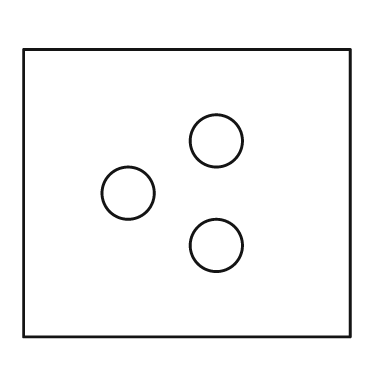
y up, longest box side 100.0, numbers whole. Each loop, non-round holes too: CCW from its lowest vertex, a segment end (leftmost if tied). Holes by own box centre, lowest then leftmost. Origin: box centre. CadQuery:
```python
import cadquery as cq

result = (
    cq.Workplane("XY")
    .moveTo(-50.0, -44.0)
    .lineTo(50.0, -44.0)
    .lineTo(50.0, 44.0)
    .lineTo(-50.0, 44.0)
    .close()
    .moveTo(9.0, -16.0)
    .circle(8.0)
    .moveTo(-18.0, 0.0)
    .circle(8.0)
    .moveTo(9.0, 16.0)
    .circle(8.0)
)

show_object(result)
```